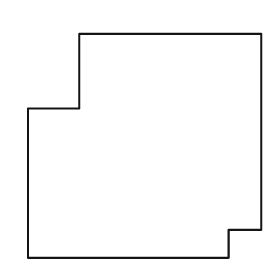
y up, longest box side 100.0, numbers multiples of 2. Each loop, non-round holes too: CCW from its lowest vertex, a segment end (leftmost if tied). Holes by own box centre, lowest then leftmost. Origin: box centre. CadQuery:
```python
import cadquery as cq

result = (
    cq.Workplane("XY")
    .moveTo(-50.0, -48.0)
    .lineTo(36.0, -48.0)
    .lineTo(36.0, -36.0)
    .lineTo(50.0, -36.0)
    .lineTo(50.0, 48.0)
    .lineTo(-28.0, 48.0)
    .lineTo(-28.0, 16.0)
    .lineTo(-50.0, 16.0)
    .close()
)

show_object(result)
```